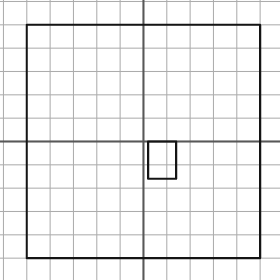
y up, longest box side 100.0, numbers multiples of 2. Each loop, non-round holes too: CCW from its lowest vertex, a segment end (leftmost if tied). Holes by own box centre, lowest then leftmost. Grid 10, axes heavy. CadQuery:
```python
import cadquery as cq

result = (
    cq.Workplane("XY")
    .moveTo(-50.0, -50.0)
    .lineTo(50.0, -50.0)
    .lineTo(50.0, 50.0)
    .lineTo(-50.0, 50.0)
    .close()
    .moveTo(2.0, -16.0)
    .lineTo(14.0, -16.0)
    .lineTo(14.0, 0.0)
    .lineTo(2.0, 0.0)
    .close()
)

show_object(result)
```